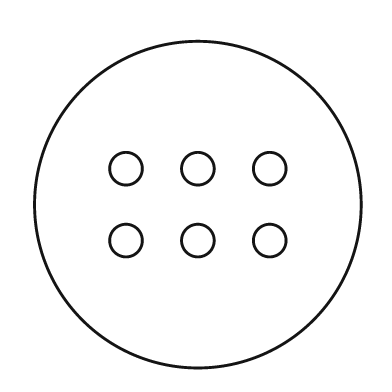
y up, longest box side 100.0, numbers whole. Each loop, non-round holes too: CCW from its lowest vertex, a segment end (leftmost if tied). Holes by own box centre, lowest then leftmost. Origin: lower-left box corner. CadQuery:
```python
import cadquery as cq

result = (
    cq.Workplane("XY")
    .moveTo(50.0, 50.0)
    .circle(50.0)
    .moveTo(28.0, 39.0)
    .circle(5.0)
    .moveTo(50.0, 39.0)
    .circle(5.0)
    .moveTo(72.0, 39.0)
    .circle(5.0)
    .moveTo(28.0, 61.0)
    .circle(5.0)
    .moveTo(50.0, 61.0)
    .circle(5.0)
    .moveTo(72.0, 61.0)
    .circle(5.0)
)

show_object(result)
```